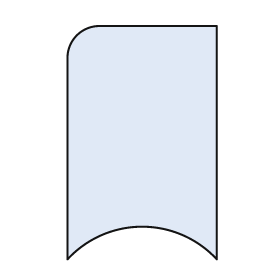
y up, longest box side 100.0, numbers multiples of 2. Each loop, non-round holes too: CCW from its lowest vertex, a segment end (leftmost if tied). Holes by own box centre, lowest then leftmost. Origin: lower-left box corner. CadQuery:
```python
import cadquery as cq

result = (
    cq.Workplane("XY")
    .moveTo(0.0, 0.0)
    .threePointArc((32.0, 14.0), (64.0, 0.0))
    .lineTo(64.0, 100.0)
    .lineTo(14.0, 100.0)
    .threePointArc((4.0, 96.0), (0.0, 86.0))
    .close()
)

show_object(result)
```